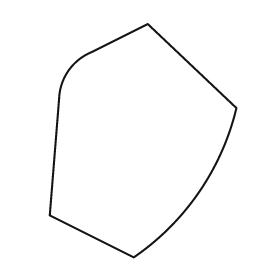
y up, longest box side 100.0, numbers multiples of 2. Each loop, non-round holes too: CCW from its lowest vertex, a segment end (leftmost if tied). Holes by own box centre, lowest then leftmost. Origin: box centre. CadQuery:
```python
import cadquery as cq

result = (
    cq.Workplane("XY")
    .moveTo(-4.0, -50.0)
    .threePointArc((24.0, -22.0), (40.0, 14.0))
    .lineTo(2.0, 50.0)
    .lineTo(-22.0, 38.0)
    .threePointArc((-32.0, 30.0), (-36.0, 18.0))
    .lineTo(-40.0, -32.0)
    .close()
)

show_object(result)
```